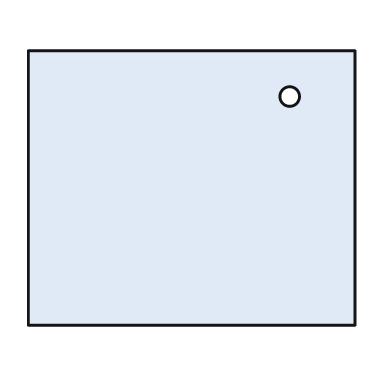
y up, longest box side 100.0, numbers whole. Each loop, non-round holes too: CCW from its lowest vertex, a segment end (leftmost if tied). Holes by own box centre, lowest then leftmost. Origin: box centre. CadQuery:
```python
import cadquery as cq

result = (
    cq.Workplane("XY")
    .moveTo(-50.0, -42.0)
    .lineTo(50.0, -42.0)
    .lineTo(50.0, 42.0)
    .lineTo(-50.0, 42.0)
    .close()
    .moveTo(30.0, 28.0)
    .circle(3.0)
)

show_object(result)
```